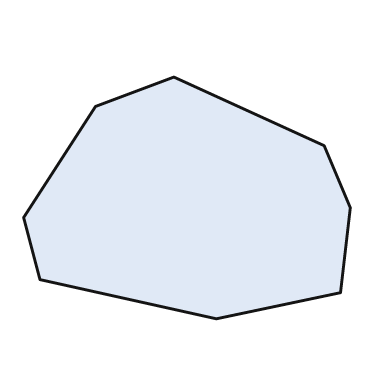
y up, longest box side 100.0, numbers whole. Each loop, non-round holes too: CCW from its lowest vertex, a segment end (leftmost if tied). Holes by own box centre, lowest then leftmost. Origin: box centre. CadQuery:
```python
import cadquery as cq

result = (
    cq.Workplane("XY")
    .moveTo(9.0, -37.0)
    .lineTo(47.0, -29.0)
    .lineTo(50.0, -3.0)
    .lineTo(42.0, 16.0)
    .lineTo(-4.0, 37.0)
    .lineTo(-28.0, 28.0)
    .lineTo(-50.0, -6.0)
    .lineTo(-45.0, -25.0)
    .close()
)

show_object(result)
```